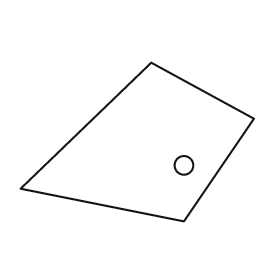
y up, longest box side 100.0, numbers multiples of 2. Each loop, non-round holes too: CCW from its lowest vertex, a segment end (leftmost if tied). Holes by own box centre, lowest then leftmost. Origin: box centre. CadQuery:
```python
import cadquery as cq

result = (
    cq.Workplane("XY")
    .moveTo(20.0, -34.0)
    .lineTo(50.0, 10.0)
    .lineTo(6.0, 34.0)
    .lineTo(-50.0, -20.0)
    .close()
    .moveTo(20.0, -10.0)
    .circle(4.0)
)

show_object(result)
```